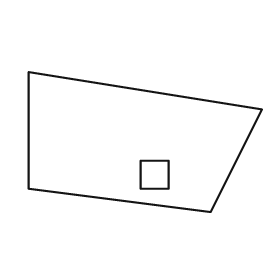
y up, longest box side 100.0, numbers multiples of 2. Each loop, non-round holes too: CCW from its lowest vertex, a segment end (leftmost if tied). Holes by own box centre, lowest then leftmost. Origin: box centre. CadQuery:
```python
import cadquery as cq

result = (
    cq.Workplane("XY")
    .moveTo(28.0, -30.0)
    .lineTo(50.0, 14.0)
    .lineTo(-50.0, 30.0)
    .lineTo(-50.0, -20.0)
    .close()
    .moveTo(-2.0, -20.0)
    .lineTo(10.0, -20.0)
    .lineTo(10.0, -8.0)
    .lineTo(-2.0, -8.0)
    .close()
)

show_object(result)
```